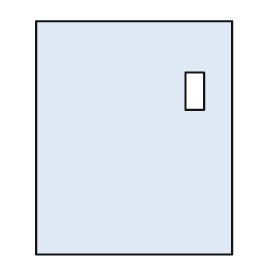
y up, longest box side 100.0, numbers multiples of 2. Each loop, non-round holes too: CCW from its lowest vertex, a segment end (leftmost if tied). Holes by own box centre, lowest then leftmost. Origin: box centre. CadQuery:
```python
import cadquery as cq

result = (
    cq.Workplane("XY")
    .moveTo(-42.0, -50.0)
    .lineTo(42.0, -50.0)
    .lineTo(42.0, 50.0)
    .lineTo(-42.0, 50.0)
    .close()
    .moveTo(22.0, 12.0)
    .lineTo(30.0, 12.0)
    .lineTo(30.0, 28.0)
    .lineTo(22.0, 28.0)
    .close()
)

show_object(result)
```